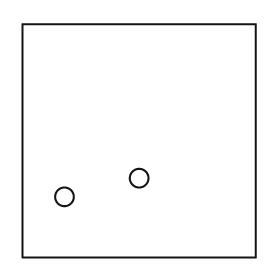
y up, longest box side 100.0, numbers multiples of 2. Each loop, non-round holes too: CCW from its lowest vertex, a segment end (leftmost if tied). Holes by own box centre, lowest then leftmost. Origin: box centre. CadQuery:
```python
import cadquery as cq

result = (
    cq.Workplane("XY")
    .moveTo(-50.0, -50.0)
    .lineTo(50.0, -50.0)
    .lineTo(50.0, 50.0)
    .lineTo(-50.0, 50.0)
    .close()
    .moveTo(-32.0, -24.0)
    .circle(4.0)
    .moveTo(0.0, -16.0)
    .circle(4.0)
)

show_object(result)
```